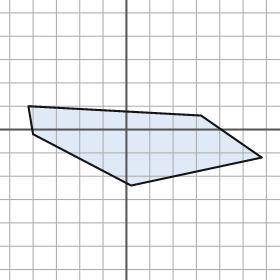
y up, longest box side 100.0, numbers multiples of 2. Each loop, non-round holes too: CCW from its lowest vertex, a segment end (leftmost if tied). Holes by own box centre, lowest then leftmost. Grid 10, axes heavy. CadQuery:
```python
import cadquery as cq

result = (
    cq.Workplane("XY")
    .moveTo(2.0, -24.0)
    .lineTo(58.0, -12.0)
    .lineTo(32.0, 6.0)
    .lineTo(-42.0, 10.0)
    .lineTo(-40.0, -2.0)
    .close()
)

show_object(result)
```